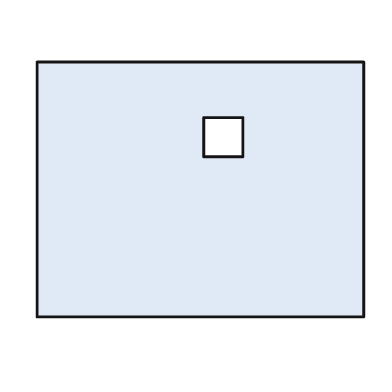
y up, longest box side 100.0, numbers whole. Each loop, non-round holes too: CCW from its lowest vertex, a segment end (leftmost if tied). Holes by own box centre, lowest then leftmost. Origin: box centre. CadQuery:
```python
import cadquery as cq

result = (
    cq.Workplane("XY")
    .moveTo(-50.0, -39.0)
    .lineTo(50.0, -39.0)
    .lineTo(50.0, 39.0)
    .lineTo(-50.0, 39.0)
    .close()
    .moveTo(1.0, 10.0)
    .lineTo(13.0, 10.0)
    .lineTo(13.0, 22.0)
    .lineTo(1.0, 22.0)
    .close()
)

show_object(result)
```